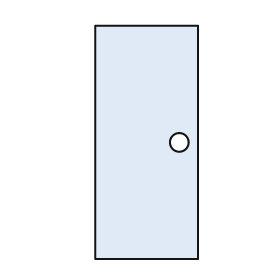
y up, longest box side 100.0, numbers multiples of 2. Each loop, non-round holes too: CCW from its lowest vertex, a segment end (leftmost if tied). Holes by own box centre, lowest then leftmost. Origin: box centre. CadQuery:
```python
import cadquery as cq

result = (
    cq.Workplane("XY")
    .moveTo(-22.0, -50.0)
    .lineTo(22.0, -50.0)
    .lineTo(22.0, 50.0)
    .lineTo(-22.0, 50.0)
    .close()
    .moveTo(14.0, 0.0)
    .circle(4.0)
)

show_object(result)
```